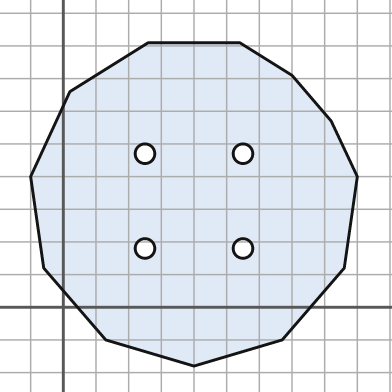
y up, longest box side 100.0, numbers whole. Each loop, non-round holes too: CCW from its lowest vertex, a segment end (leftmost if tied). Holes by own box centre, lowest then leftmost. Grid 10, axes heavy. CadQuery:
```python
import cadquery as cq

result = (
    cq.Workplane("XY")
    .moveTo(40.0, -18.0)
    .lineTo(67.0, -10.0)
    .lineTo(86.0, 12.0)
    .lineTo(90.0, 40.0)
    .lineTo(82.0, 57.0)
    .lineTo(70.0, 71.0)
    .lineTo(54.0, 81.0)
    .lineTo(26.0, 81.0)
    .lineTo(2.0, 66.0)
    .lineTo(-10.0, 40.0)
    .lineTo(-6.0, 12.0)
    .lineTo(13.0, -10.0)
    .close()
    .moveTo(25.0, 18.0)
    .circle(3.0)
    .moveTo(55.0, 18.0)
    .circle(3.0)
    .moveTo(25.0, 47.0)
    .circle(3.0)
    .moveTo(55.0, 47.0)
    .circle(3.0)
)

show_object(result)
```